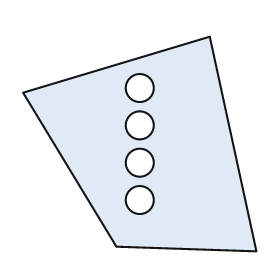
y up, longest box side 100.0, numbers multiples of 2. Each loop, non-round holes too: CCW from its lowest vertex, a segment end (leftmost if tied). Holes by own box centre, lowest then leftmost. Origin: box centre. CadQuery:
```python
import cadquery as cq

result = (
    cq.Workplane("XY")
    .moveTo(50.0, -46.0)
    .lineTo(30.0, 46.0)
    .lineTo(-50.0, 22.0)
    .lineTo(-10.0, -44.0)
    .close()
    .moveTo(0.0, -24.0)
    .circle(6.0)
    .moveTo(0.0, -8.0)
    .circle(6.0)
    .moveTo(0.0, 8.0)
    .circle(6.0)
    .moveTo(0.0, 24.0)
    .circle(6.0)
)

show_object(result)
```